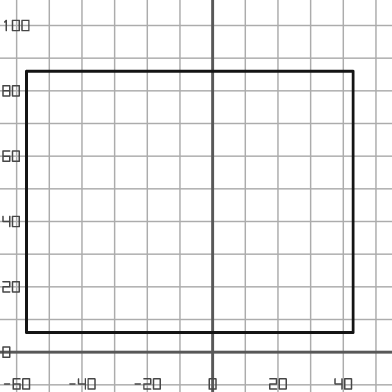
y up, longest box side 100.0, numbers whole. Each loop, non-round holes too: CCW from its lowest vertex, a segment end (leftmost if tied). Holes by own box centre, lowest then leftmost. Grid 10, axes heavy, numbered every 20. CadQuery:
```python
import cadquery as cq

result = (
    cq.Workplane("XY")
    .moveTo(-57.0, 6.0)
    .lineTo(43.0, 6.0)
    .lineTo(43.0, 86.0)
    .lineTo(-57.0, 86.0)
    .close()
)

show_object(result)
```